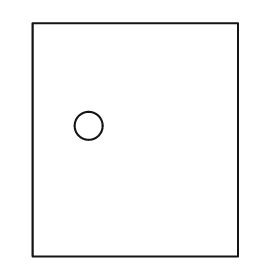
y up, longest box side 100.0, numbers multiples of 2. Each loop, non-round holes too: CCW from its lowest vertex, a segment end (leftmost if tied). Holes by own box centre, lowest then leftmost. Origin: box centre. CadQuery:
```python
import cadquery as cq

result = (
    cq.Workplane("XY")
    .moveTo(-44.0, -50.0)
    .lineTo(44.0, -50.0)
    .lineTo(44.0, 50.0)
    .lineTo(-44.0, 50.0)
    .close()
    .moveTo(-20.0, 6.0)
    .circle(6.0)
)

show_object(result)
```